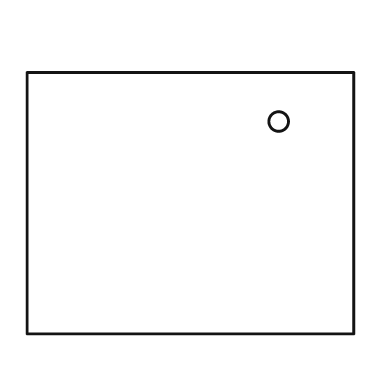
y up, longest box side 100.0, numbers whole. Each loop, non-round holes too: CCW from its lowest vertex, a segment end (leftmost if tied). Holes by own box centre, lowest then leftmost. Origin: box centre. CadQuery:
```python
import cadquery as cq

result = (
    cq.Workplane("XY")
    .moveTo(-50.0, -40.0)
    .lineTo(50.0, -40.0)
    .lineTo(50.0, 40.0)
    .lineTo(-50.0, 40.0)
    .close()
    .moveTo(27.0, 25.0)
    .circle(3.0)
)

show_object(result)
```